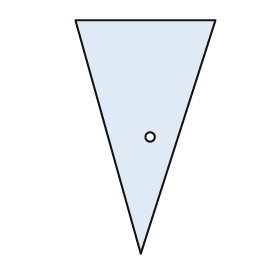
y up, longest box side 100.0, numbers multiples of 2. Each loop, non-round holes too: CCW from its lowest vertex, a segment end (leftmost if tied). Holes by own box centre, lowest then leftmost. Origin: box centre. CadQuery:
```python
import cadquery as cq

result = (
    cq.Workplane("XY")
    .moveTo(-2.0, -50.0)
    .lineTo(30.0, 50.0)
    .lineTo(-30.0, 50.0)
    .close()
    .moveTo(2.0, 0.0)
    .circle(2.0)
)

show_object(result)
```